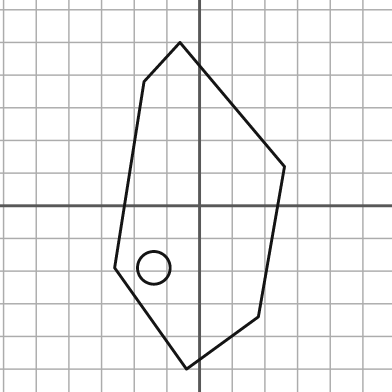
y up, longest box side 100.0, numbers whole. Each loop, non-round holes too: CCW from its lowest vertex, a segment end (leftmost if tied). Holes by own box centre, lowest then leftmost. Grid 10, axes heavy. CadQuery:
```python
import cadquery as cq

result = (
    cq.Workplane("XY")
    .moveTo(-4.0, -50.0)
    .lineTo(18.0, -34.0)
    .lineTo(26.0, 12.0)
    .lineTo(-6.0, 50.0)
    .lineTo(-17.0, 38.0)
    .lineTo(-26.0, -19.0)
    .close()
    .moveTo(-14.0, -19.0)
    .circle(5.0)
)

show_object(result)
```